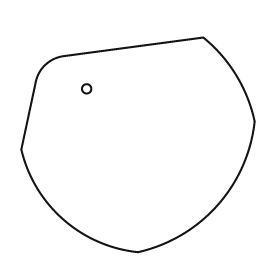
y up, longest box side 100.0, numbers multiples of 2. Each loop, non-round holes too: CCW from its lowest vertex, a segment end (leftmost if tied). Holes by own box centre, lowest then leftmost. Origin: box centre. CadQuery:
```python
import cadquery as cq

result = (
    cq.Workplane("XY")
    .moveTo(0.0, -46.0)
    .threePointArc((34.0, -26.0), (50.0, 10.0))
    .threePointArc((42.0, 30.0), (28.0, 46.0))
    .lineTo(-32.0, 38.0)
    .threePointArc((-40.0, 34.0), (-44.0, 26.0))
    .lineTo(-50.0, -2.0)
    .threePointArc((-32.0, -32.0), (0.0, -46.0))
    .close()
    .moveTo(-22.0, 24.0)
    .circle(2.0)
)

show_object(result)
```